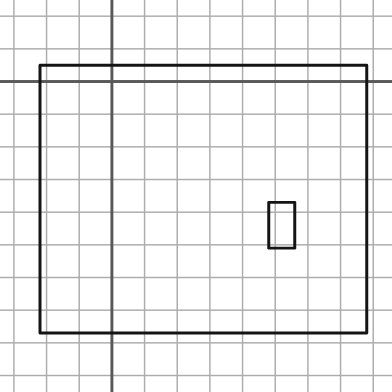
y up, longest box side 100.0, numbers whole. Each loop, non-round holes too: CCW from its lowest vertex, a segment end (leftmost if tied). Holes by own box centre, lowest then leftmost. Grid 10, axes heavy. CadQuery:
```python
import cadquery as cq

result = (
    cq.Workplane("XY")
    .moveTo(-22.0, -77.0)
    .lineTo(78.0, -77.0)
    .lineTo(78.0, 5.0)
    .lineTo(-22.0, 5.0)
    .close()
    .moveTo(48.0, -51.0)
    .lineTo(56.0, -51.0)
    .lineTo(56.0, -37.0)
    .lineTo(48.0, -37.0)
    .close()
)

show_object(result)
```